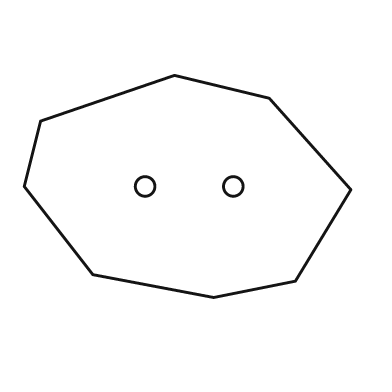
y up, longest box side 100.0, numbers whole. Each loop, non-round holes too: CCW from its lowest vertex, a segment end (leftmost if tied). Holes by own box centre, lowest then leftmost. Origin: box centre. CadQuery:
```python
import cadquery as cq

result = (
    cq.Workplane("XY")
    .moveTo(8.0, -34.0)
    .lineTo(33.0, -29.0)
    .lineTo(50.0, -1.0)
    .lineTo(25.0, 27.0)
    .lineTo(-4.0, 34.0)
    .lineTo(-45.0, 20.0)
    .lineTo(-50.0, 0.0)
    .lineTo(-29.0, -27.0)
    .close()
    .moveTo(-13.0, 0.0)
    .circle(3.0)
    .moveTo(14.0, 0.0)
    .circle(3.0)
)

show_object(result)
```